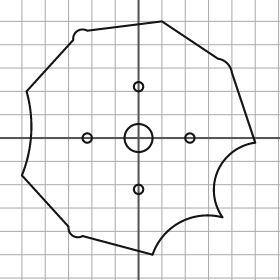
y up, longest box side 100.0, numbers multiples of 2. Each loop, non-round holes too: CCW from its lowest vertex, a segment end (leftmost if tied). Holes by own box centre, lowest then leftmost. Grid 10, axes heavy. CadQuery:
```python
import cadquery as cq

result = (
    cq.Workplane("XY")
    .moveTo(6.0, -50.0)
    .threePointArc((18.0, -36.0), (36.0, -34.0))
    .threePointArc((34.0, -14.0), (50.0, -2.0))
    .lineTo(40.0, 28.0)
    .threePointArc((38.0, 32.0), (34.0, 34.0))
    .lineTo(10.0, 50.0)
    .lineTo(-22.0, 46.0)
    .threePointArc((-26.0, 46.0), (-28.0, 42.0))
    .lineTo(-48.0, 20.0)
    .threePointArc((-46.0, 2.0), (-50.0, -16.0))
    .lineTo(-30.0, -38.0)
    .threePointArc((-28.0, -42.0), (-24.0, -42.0))
    .close()
    .moveTo(0.0, -22.0)
    .circle(2.0)
    .moveTo(-22.0, 0.0)
    .circle(2.0)
    .moveTo(0.0, 0.0)
    .circle(6.0)
    .moveTo(22.0, 0.0)
    .circle(2.0)
    .moveTo(0.0, 22.0)
    .circle(2.0)
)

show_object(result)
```